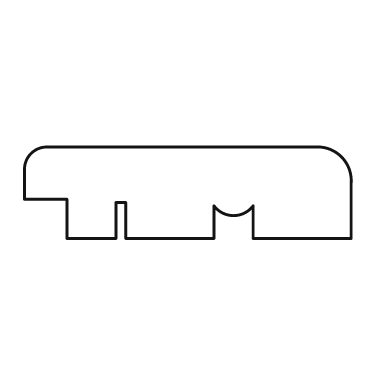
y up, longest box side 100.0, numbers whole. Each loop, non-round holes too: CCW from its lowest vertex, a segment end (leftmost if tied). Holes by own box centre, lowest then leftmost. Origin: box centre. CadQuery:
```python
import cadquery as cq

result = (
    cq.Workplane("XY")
    .moveTo(-37.0, -14.0)
    .lineTo(-22.0, -14.0)
    .lineTo(-22.0, -3.0)
    .lineTo(-19.0, -3.0)
    .lineTo(-19.0, -14.0)
    .lineTo(8.0, -14.0)
    .lineTo(8.0, -4.0)
    .threePointArc((14.0, -7.0), (20.0, -4.0))
    .lineTo(20.0, -14.0)
    .lineTo(50.0, -14.0)
    .lineTo(50.0, 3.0)
    .threePointArc((47.0, 11.0), (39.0, 14.0))
    .lineTo(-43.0, 14.0)
    .threePointArc((-48.0, 12.0), (-50.0, 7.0))
    .lineTo(-50.0, -2.0)
    .lineTo(-37.0, -2.0)
    .close()
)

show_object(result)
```